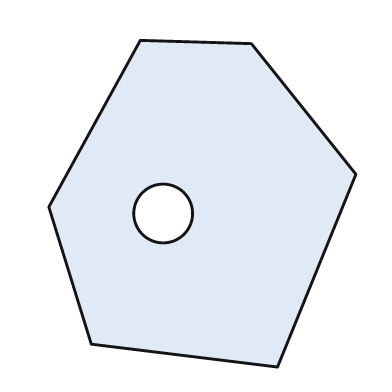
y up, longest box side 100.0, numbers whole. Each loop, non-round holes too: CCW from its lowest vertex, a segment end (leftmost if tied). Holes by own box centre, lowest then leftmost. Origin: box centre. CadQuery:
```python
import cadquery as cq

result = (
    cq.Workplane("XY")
    .moveTo(23.0, -50.0)
    .lineTo(47.0, 9.0)
    .lineTo(15.0, 49.0)
    .lineTo(-19.0, 50.0)
    .lineTo(-47.0, -1.0)
    .lineTo(-34.0, -43.0)
    .close()
    .moveTo(-12.0, -3.0)
    .circle(9.0)
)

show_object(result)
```